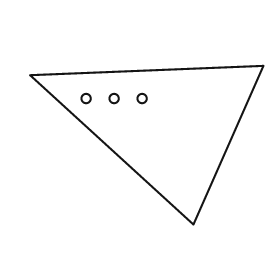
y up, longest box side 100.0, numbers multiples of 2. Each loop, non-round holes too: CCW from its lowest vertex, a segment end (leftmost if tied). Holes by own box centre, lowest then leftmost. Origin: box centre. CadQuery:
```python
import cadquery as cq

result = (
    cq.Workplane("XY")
    .moveTo(20.0, -34.0)
    .lineTo(50.0, 34.0)
    .lineTo(-50.0, 30.0)
    .close()
    .moveTo(-26.0, 20.0)
    .circle(2.0)
    .moveTo(-14.0, 20.0)
    .circle(2.0)
    .moveTo(-2.0, 20.0)
    .circle(2.0)
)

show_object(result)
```